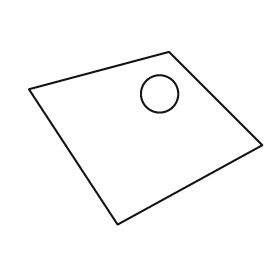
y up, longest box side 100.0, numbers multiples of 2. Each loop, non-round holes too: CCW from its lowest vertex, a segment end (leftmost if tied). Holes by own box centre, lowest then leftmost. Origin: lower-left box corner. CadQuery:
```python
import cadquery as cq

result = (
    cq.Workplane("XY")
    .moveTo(38.0, 0.0)
    .lineTo(100.0, 34.0)
    .lineTo(60.0, 74.0)
    .lineTo(0.0, 58.0)
    .close()
    .moveTo(56.0, 56.0)
    .circle(8.0)
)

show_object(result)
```